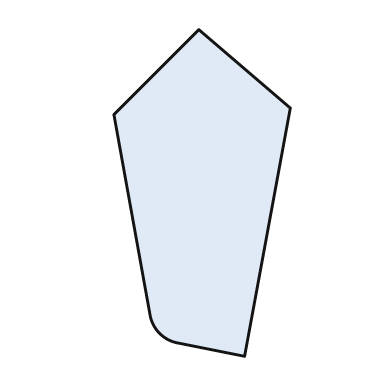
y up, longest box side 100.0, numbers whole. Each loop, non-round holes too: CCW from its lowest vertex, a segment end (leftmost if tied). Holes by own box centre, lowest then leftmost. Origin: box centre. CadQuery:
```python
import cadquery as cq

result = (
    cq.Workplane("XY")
    .moveTo(13.0, -50.0)
    .lineTo(27.0, 26.0)
    .lineTo(-1.0, 50.0)
    .lineTo(-27.0, 24.0)
    .lineTo(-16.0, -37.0)
    .threePointArc((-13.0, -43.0), (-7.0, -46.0))
    .close()
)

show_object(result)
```